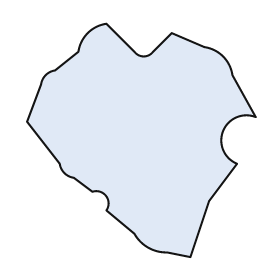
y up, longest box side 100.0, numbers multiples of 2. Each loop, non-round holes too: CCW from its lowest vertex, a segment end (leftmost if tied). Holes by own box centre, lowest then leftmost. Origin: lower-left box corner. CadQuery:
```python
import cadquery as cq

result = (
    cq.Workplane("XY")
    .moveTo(70.0, 0.0)
    .lineTo(78.0, 24.0)
    .lineTo(90.0, 40.0)
    .threePointArc((84.0, 54.0), (98.0, 60.0))
    .lineTo(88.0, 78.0)
    .threePointArc((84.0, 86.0), (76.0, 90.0))
    .lineTo(62.0, 96.0)
    .lineTo(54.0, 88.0)
    .threePointArc((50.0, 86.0), (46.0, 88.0))
    .lineTo(34.0, 100.0)
    .threePointArc((26.0, 96.0), (22.0, 88.0))
    .lineTo(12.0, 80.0)
    .threePointArc((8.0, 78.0), (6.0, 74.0))
    .lineTo(0.0, 58.0)
    .lineTo(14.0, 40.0)
    .threePointArc((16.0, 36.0), (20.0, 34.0))
    .lineTo(28.0, 28.0)
    .threePointArc((34.0, 26.0), (34.0, 20.0))
    .lineTo(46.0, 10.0)
    .threePointArc((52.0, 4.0), (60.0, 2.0))
    .close()
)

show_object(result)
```